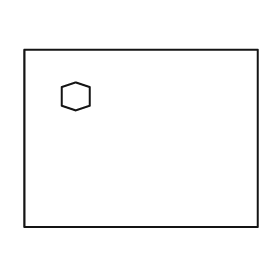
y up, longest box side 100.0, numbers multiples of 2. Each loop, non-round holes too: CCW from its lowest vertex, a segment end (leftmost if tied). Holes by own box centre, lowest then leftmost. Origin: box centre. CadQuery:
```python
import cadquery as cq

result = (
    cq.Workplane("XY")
    .moveTo(-50.0, -38.0)
    .lineTo(50.0, -38.0)
    .lineTo(50.0, 38.0)
    .lineTo(-50.0, 38.0)
    .close()
    .moveTo(-28.0, 12.0)
    .lineTo(-22.0, 14.0)
    .lineTo(-22.0, 22.0)
    .lineTo(-28.0, 24.0)
    .lineTo(-34.0, 22.0)
    .lineTo(-34.0, 14.0)
    .close()
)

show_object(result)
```